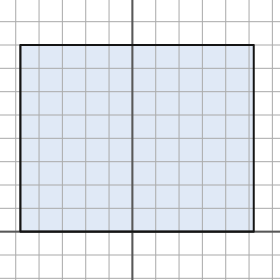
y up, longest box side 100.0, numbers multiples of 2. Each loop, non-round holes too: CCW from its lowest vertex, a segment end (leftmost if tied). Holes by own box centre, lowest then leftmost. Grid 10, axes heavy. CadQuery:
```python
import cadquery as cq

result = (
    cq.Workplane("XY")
    .moveTo(-48.0, 0.0)
    .lineTo(52.0, 0.0)
    .lineTo(52.0, 80.0)
    .lineTo(-48.0, 80.0)
    .close()
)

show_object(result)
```